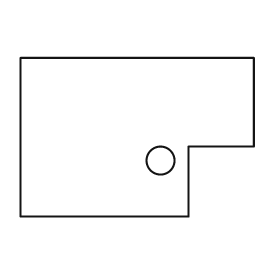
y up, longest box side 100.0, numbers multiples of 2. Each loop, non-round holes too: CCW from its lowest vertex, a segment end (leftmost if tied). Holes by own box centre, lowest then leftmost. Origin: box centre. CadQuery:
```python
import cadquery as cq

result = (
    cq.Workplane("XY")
    .moveTo(-50.0, -34.0)
    .lineTo(22.0, -34.0)
    .lineTo(22.0, -4.0)
    .lineTo(50.0, -4.0)
    .lineTo(50.0, 34.0)
    .lineTo(-50.0, 34.0)
    .close()
    .moveTo(10.0, -10.0)
    .circle(6.0)
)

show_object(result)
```